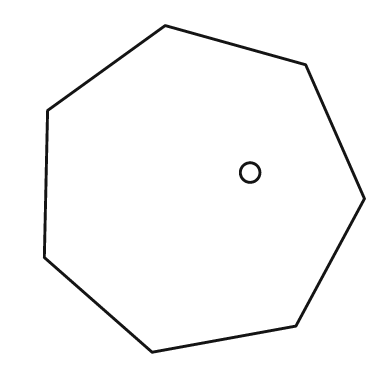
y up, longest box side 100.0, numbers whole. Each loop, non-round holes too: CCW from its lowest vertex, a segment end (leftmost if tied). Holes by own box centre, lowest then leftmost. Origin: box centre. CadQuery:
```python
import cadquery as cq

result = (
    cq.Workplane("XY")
    .moveTo(-16.0, -50.0)
    .lineTo(28.0, -42.0)
    .lineTo(49.0, -3.0)
    .lineTo(31.0, 38.0)
    .lineTo(-12.0, 50.0)
    .lineTo(-48.0, 24.0)
    .lineTo(-49.0, -21.0)
    .close()
    .moveTo(14.0, 5.0)
    .circle(3.0)
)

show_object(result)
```